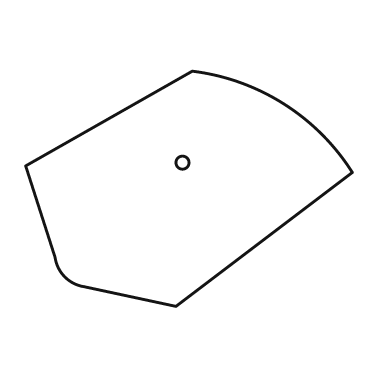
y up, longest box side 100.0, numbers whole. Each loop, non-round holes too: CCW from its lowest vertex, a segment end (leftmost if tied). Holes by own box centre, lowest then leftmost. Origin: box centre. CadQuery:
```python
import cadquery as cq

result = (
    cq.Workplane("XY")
    .moveTo(-4.0, -36.0)
    .lineTo(50.0, 5.0)
    .threePointArc((29.0, 26.0), (1.0, 36.0))
    .lineTo(-50.0, 7.0)
    .lineTo(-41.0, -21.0)
    .threePointArc((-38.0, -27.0), (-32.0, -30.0))
    .close()
    .moveTo(-2.0, 8.0)
    .circle(2.0)
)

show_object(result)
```